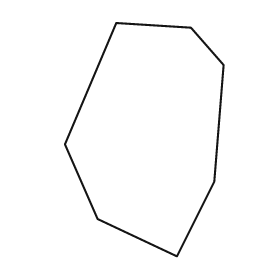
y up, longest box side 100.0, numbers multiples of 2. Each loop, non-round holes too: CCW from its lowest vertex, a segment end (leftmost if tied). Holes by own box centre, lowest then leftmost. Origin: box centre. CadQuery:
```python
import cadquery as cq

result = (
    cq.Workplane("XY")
    .moveTo(14.0, -50.0)
    .lineTo(30.0, -18.0)
    .lineTo(34.0, 32.0)
    .lineTo(20.0, 48.0)
    .lineTo(-12.0, 50.0)
    .lineTo(-34.0, -2.0)
    .lineTo(-20.0, -34.0)
    .close()
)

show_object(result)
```